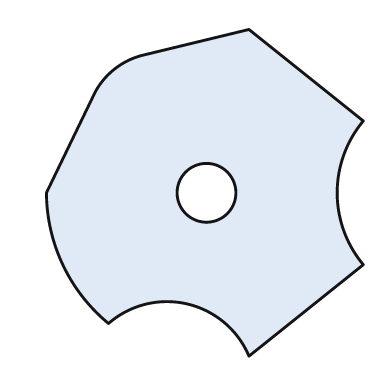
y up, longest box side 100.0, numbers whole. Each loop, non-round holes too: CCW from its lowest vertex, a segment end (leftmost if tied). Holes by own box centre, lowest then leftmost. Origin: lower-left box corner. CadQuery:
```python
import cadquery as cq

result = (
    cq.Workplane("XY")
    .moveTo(62.0, 0.0)
    .lineTo(97.0, 28.0)
    .threePointArc((89.0, 50.0), (97.0, 72.0))
    .lineTo(62.0, 100.0)
    .lineTo(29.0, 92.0)
    .threePointArc((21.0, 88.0), (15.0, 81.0))
    .lineTo(0.0, 50.0)
    .threePointArc((5.0, 28.0), (19.0, 10.0))
    .threePointArc((43.0, 16.0), (62.0, 0.0))
    .close()
    .moveTo(49.0, 50.0)
    .circle(9.0)
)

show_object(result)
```